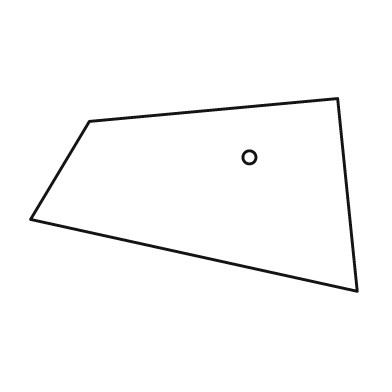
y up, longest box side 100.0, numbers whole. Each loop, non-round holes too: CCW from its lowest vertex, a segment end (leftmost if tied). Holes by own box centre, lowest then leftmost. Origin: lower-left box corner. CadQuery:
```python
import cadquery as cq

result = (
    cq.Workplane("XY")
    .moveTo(100.0, 0.0)
    .lineTo(94.0, 59.0)
    .lineTo(18.0, 52.0)
    .lineTo(0.0, 22.0)
    .close()
    .moveTo(67.0, 41.0)
    .circle(2.0)
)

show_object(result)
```